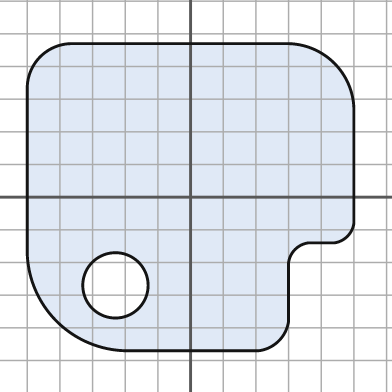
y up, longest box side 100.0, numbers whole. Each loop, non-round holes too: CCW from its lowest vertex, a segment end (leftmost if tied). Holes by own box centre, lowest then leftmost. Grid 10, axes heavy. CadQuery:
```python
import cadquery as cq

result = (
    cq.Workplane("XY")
    .moveTo(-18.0, -47.0)
    .lineTo(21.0, -47.0)
    .threePointArc((27.0, -44.0), (30.0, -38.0))
    .lineTo(30.0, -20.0)
    .threePointArc((32.0, -16.0), (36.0, -14.0))
    .lineTo(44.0, -14.0)
    .threePointArc((48.0, -12.0), (50.0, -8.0))
    .lineTo(50.0, 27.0)
    .threePointArc((44.0, 41.0), (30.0, 47.0))
    .lineTo(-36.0, 47.0)
    .threePointArc((-46.0, 43.0), (-50.0, 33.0))
    .lineTo(-50.0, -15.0)
    .threePointArc((-41.0, -38.0), (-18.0, -47.0))
    .close()
    .moveTo(-23.0, -27.0)
    .circle(10.0)
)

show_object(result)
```